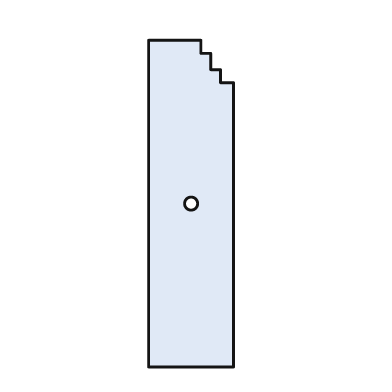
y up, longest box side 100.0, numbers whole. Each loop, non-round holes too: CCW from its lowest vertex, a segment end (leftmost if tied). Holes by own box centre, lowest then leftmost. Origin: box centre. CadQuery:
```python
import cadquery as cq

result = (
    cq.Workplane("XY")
    .moveTo(-13.0, -50.0)
    .lineTo(13.0, -50.0)
    .lineTo(13.0, 37.0)
    .lineTo(9.0, 37.0)
    .lineTo(9.0, 41.0)
    .lineTo(6.0, 41.0)
    .lineTo(6.0, 46.0)
    .lineTo(3.0, 46.0)
    .lineTo(3.0, 50.0)
    .lineTo(-13.0, 50.0)
    .close()
    .moveTo(0.0, 0.0)
    .circle(2.0)
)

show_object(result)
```